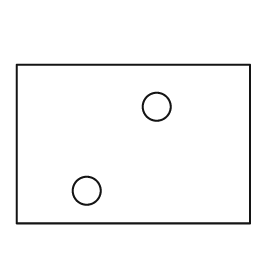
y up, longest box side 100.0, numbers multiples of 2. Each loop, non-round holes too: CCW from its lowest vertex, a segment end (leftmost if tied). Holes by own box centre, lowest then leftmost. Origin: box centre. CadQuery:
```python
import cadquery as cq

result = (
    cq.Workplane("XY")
    .moveTo(-50.0, -34.0)
    .lineTo(50.0, -34.0)
    .lineTo(50.0, 34.0)
    .lineTo(-50.0, 34.0)
    .close()
    .moveTo(-20.0, -20.0)
    .circle(6.0)
    .moveTo(10.0, 16.0)
    .circle(6.0)
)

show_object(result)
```